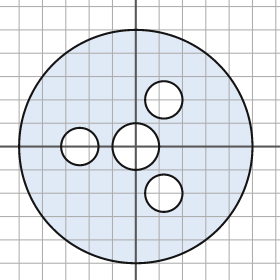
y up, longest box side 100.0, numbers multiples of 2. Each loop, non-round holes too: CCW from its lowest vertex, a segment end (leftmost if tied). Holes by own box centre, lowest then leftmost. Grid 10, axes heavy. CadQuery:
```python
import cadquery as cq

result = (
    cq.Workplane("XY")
    .moveTo(0.0, 0.0)
    .circle(50.0)
    .moveTo(12.0, -20.0)
    .circle(8.0)
    .moveTo(-24.0, 0.0)
    .circle(8.0)
    .moveTo(0.0, 0.0)
    .circle(10.0)
    .moveTo(12.0, 20.0)
    .circle(8.0)
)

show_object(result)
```